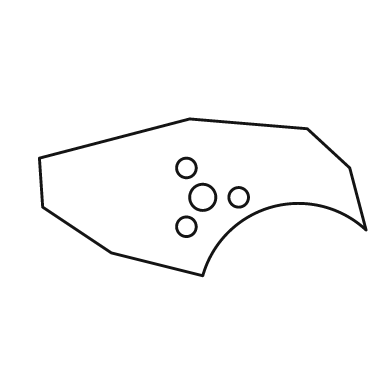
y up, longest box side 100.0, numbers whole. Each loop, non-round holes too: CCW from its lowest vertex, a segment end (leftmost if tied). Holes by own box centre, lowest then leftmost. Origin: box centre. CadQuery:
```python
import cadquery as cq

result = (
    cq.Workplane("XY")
    .moveTo(0.0, -24.0)
    .threePointArc((21.0, -3.0), (50.0, -10.0))
    .lineTo(45.0, 9.0)
    .lineTo(32.0, 21.0)
    .lineTo(-4.0, 24.0)
    .lineTo(-50.0, 12.0)
    .lineTo(-49.0, -3.0)
    .lineTo(-28.0, -17.0)
    .close()
    .moveTo(-5.0, -9.0)
    .circle(3.0)
    .moveTo(0.0, 0.0)
    .circle(4.0)
    .moveTo(11.0, 0.0)
    .circle(3.0)
    .moveTo(-5.0, 9.0)
    .circle(3.0)
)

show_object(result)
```